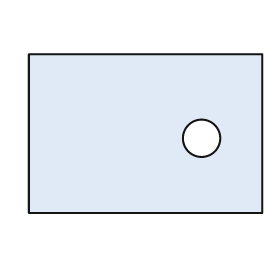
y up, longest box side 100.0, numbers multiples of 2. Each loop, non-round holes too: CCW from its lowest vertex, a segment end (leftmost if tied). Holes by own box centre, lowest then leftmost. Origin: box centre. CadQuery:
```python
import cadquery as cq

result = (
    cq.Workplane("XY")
    .moveTo(-50.0, -34.0)
    .lineTo(50.0, -34.0)
    .lineTo(50.0, 34.0)
    .lineTo(-50.0, 34.0)
    .close()
    .moveTo(24.0, -2.0)
    .circle(8.0)
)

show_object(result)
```